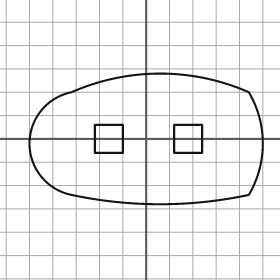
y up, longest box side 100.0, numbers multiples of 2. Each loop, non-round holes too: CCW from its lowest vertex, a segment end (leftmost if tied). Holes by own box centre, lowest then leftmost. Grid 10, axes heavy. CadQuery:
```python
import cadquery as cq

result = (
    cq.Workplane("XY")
    .moveTo(-32.0, -24.0)
    .threePointArc((6.0, -28.0), (44.0, -24.0))
    .threePointArc((50.0, -2.0), (44.0, 20.0))
    .threePointArc((6.0, 28.0), (-32.0, 20.0))
    .threePointArc((-50.0, -2.0), (-32.0, -24.0))
    .close()
    .moveTo(-22.0, -6.0)
    .lineTo(-10.0, -6.0)
    .lineTo(-10.0, 6.0)
    .lineTo(-22.0, 6.0)
    .close()
    .moveTo(12.0, -6.0)
    .lineTo(24.0, -6.0)
    .lineTo(24.0, 6.0)
    .lineTo(12.0, 6.0)
    .close()
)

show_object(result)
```